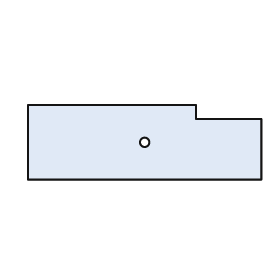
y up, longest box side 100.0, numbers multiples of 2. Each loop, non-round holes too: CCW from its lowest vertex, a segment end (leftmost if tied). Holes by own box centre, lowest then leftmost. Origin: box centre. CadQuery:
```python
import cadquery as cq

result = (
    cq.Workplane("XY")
    .moveTo(-50.0, -16.0)
    .lineTo(50.0, -16.0)
    .lineTo(50.0, 10.0)
    .lineTo(22.0, 10.0)
    .lineTo(22.0, 16.0)
    .lineTo(-50.0, 16.0)
    .close()
    .moveTo(0.0, 0.0)
    .circle(2.0)
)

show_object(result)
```